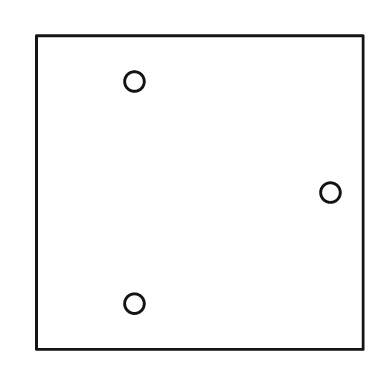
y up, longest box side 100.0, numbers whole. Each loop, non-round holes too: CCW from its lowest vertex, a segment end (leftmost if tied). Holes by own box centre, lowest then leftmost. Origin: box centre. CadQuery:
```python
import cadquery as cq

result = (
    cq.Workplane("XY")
    .moveTo(-50.0, -48.0)
    .lineTo(50.0, -48.0)
    .lineTo(50.0, 48.0)
    .lineTo(-50.0, 48.0)
    .close()
    .moveTo(-20.0, -34.0)
    .circle(3.0)
    .moveTo(40.0, 0.0)
    .circle(3.0)
    .moveTo(-20.0, 34.0)
    .circle(3.0)
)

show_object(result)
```